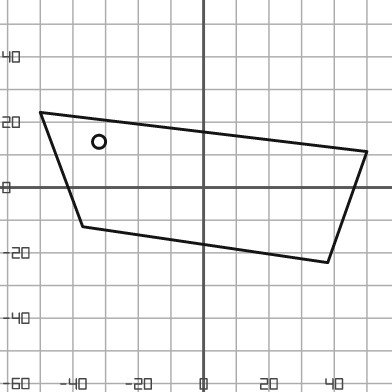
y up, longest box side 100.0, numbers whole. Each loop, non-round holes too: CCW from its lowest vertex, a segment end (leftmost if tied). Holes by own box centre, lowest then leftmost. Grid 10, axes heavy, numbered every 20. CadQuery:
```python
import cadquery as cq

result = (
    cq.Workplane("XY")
    .moveTo(38.0, -23.0)
    .lineTo(50.0, 11.0)
    .lineTo(-50.0, 23.0)
    .lineTo(-37.0, -12.0)
    .close()
    .moveTo(-32.0, 14.0)
    .circle(2.0)
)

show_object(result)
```